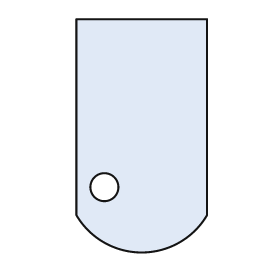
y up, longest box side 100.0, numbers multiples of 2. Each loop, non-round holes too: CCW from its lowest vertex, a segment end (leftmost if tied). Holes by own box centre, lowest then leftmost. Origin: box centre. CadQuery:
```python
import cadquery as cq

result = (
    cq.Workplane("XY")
    .moveTo(-28.0, -34.0)
    .threePointArc((0.0, -50.0), (28.0, -34.0))
    .lineTo(28.0, 50.0)
    .lineTo(-28.0, 50.0)
    .close()
    .moveTo(-16.0, -22.0)
    .circle(6.0)
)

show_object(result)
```